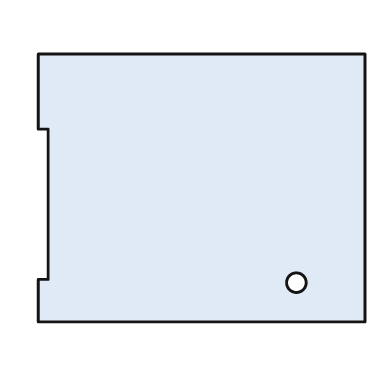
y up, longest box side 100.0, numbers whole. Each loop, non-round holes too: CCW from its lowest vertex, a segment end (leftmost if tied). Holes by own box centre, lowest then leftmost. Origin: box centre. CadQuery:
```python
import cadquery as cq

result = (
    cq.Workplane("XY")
    .moveTo(-50.0, -41.0)
    .lineTo(50.0, -41.0)
    .lineTo(50.0, 41.0)
    .lineTo(-50.0, 41.0)
    .lineTo(-50.0, 18.0)
    .lineTo(-47.0, 18.0)
    .lineTo(-47.0, -28.0)
    .lineTo(-50.0, -28.0)
    .close()
    .moveTo(29.0, -29.0)
    .circle(3.0)
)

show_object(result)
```